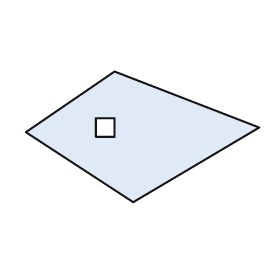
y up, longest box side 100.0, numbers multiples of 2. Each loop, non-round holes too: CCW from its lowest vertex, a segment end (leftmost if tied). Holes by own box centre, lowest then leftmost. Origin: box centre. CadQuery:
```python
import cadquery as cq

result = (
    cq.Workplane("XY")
    .moveTo(-4.0, -28.0)
    .lineTo(50.0, 4.0)
    .lineTo(-12.0, 28.0)
    .lineTo(-50.0, 2.0)
    .close()
    .moveTo(-20.0, 0.0)
    .lineTo(-12.0, 0.0)
    .lineTo(-12.0, 8.0)
    .lineTo(-20.0, 8.0)
    .close()
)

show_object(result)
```